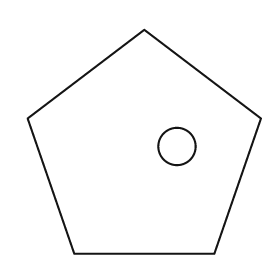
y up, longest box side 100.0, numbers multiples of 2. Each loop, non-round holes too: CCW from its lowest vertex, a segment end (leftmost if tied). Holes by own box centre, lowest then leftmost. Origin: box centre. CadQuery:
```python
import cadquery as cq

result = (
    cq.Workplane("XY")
    .moveTo(-30.0, -48.0)
    .lineTo(30.0, -48.0)
    .lineTo(50.0, 10.0)
    .lineTo(0.0, 48.0)
    .lineTo(-50.0, 10.0)
    .close()
    .moveTo(14.0, -2.0)
    .circle(8.0)
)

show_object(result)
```